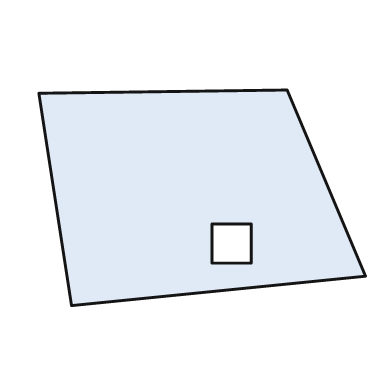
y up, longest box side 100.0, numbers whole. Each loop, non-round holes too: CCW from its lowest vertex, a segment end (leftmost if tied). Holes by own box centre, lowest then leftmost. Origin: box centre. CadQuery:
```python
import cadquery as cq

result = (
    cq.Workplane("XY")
    .moveTo(-40.0, -33.0)
    .lineTo(50.0, -24.0)
    .lineTo(26.0, 33.0)
    .lineTo(-50.0, 32.0)
    .close()
    .moveTo(3.0, -20.0)
    .lineTo(15.0, -20.0)
    .lineTo(15.0, -8.0)
    .lineTo(3.0, -8.0)
    .close()
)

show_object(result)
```